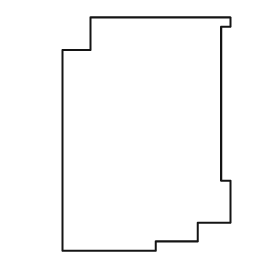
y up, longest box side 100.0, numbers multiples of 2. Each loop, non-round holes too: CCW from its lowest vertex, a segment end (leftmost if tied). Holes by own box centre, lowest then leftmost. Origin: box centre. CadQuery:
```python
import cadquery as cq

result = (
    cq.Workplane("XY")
    .moveTo(-36.0, -50.0)
    .lineTo(4.0, -50.0)
    .lineTo(4.0, -46.0)
    .lineTo(22.0, -46.0)
    .lineTo(22.0, -38.0)
    .lineTo(36.0, -38.0)
    .lineTo(36.0, -20.0)
    .lineTo(32.0, -20.0)
    .lineTo(32.0, 46.0)
    .lineTo(36.0, 46.0)
    .lineTo(36.0, 50.0)
    .lineTo(-24.0, 50.0)
    .lineTo(-24.0, 36.0)
    .lineTo(-36.0, 36.0)
    .close()
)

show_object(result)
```